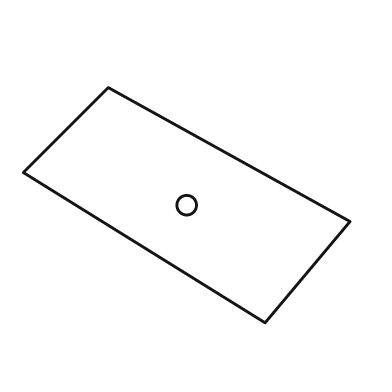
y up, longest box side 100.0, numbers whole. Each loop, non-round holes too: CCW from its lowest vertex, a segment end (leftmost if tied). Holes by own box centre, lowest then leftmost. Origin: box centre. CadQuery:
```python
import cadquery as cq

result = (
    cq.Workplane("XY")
    .moveTo(24.0, -36.0)
    .lineTo(50.0, -5.0)
    .lineTo(-24.0, 36.0)
    .lineTo(-50.0, 10.0)
    .close()
    .moveTo(0.0, 0.0)
    .circle(3.0)
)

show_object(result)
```